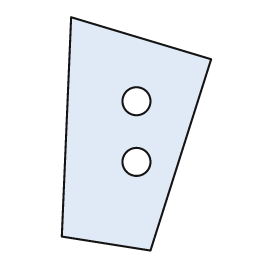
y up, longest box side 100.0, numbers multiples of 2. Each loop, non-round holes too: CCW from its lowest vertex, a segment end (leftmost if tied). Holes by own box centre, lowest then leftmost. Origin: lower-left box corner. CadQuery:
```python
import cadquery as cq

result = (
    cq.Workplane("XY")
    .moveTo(38.0, 0.0)
    .lineTo(64.0, 82.0)
    .lineTo(4.0, 100.0)
    .lineTo(0.0, 6.0)
    .close()
    .moveTo(32.0, 38.0)
    .circle(6.0)
    .moveTo(32.0, 64.0)
    .circle(6.0)
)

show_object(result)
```